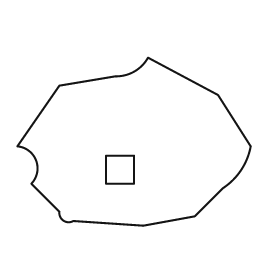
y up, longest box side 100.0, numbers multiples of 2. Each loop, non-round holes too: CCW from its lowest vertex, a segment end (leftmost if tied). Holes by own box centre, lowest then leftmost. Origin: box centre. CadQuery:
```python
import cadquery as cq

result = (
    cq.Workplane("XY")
    .moveTo(4.0, -36.0)
    .lineTo(26.0, -32.0)
    .lineTo(38.0, -20.0)
    .threePointArc((46.0, -12.0), (50.0, -2.0))
    .lineTo(36.0, 20.0)
    .lineTo(6.0, 36.0)
    .threePointArc((0.0, 30.0), (-8.0, 28.0))
    .lineTo(-32.0, 24.0)
    .lineTo(-50.0, -2.0)
    .threePointArc((-42.0, -8.0), (-44.0, -18.0))
    .lineTo(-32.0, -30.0)
    .threePointArc((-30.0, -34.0), (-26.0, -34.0))
    .close()
    .moveTo(-12.0, -18.0)
    .lineTo(0.0, -18.0)
    .lineTo(0.0, -6.0)
    .lineTo(-12.0, -6.0)
    .close()
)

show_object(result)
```